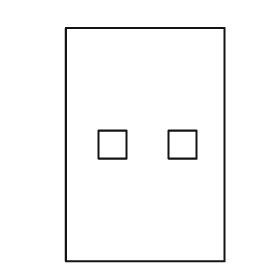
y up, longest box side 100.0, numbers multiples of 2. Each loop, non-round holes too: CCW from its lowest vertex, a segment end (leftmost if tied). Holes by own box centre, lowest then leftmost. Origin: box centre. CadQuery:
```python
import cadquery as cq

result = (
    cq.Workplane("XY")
    .moveTo(-34.0, -50.0)
    .lineTo(34.0, -50.0)
    .lineTo(34.0, 50.0)
    .lineTo(-34.0, 50.0)
    .close()
    .moveTo(-20.0, -6.0)
    .lineTo(-8.0, -6.0)
    .lineTo(-8.0, 6.0)
    .lineTo(-20.0, 6.0)
    .close()
    .moveTo(10.0, -6.0)
    .lineTo(22.0, -6.0)
    .lineTo(22.0, 6.0)
    .lineTo(10.0, 6.0)
    .close()
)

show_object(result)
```